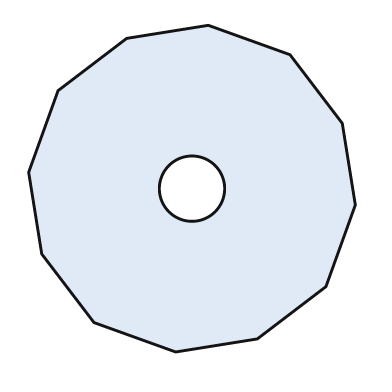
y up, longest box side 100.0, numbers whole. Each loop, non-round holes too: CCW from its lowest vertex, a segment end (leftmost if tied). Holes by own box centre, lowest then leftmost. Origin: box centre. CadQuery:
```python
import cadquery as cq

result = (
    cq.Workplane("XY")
    .moveTo(-5.0, -50.0)
    .lineTo(20.0, -46.0)
    .lineTo(41.0, -30.0)
    .lineTo(50.0, -5.0)
    .lineTo(46.0, 20.0)
    .lineTo(30.0, 41.0)
    .lineTo(5.0, 50.0)
    .lineTo(-20.0, 46.0)
    .lineTo(-41.0, 30.0)
    .lineTo(-50.0, 5.0)
    .lineTo(-46.0, -20.0)
    .lineTo(-30.0, -41.0)
    .close()
    .moveTo(0.0, 0.0)
    .circle(10.0)
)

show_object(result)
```